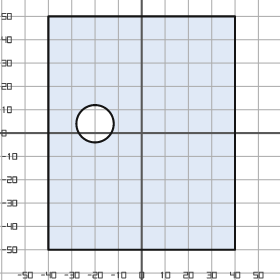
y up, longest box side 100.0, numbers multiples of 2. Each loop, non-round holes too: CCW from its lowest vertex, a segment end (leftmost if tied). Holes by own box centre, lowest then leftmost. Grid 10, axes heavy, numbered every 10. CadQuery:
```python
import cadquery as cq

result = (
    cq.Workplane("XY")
    .moveTo(-40.0, -50.0)
    .lineTo(40.0, -50.0)
    .lineTo(40.0, 50.0)
    .lineTo(-40.0, 50.0)
    .close()
    .moveTo(-20.0, 4.0)
    .circle(8.0)
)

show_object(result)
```